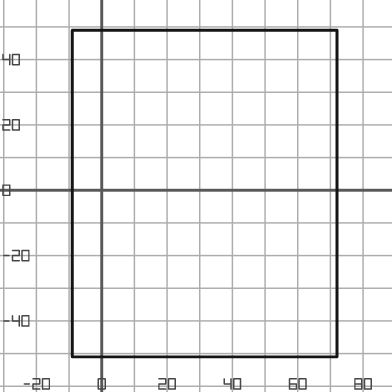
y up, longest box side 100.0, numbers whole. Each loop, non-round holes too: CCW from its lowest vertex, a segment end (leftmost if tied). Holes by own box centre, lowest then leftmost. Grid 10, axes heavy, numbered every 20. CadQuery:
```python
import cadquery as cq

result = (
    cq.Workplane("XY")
    .moveTo(-9.0, -51.0)
    .lineTo(72.0, -51.0)
    .lineTo(72.0, 49.0)
    .lineTo(-9.0, 49.0)
    .close()
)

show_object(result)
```